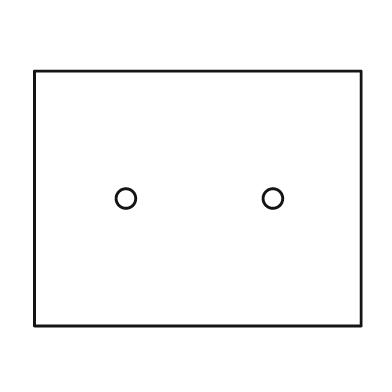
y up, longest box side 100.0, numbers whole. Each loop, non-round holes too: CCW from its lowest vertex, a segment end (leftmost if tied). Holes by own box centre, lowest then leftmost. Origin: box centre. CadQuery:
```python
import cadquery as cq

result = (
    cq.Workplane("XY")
    .moveTo(-50.0, -39.0)
    .lineTo(50.0, -39.0)
    .lineTo(50.0, 39.0)
    .lineTo(-50.0, 39.0)
    .close()
    .moveTo(-22.0, 0.0)
    .circle(3.0)
    .moveTo(23.0, 0.0)
    .circle(3.0)
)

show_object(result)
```